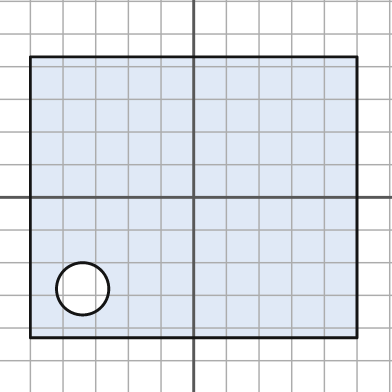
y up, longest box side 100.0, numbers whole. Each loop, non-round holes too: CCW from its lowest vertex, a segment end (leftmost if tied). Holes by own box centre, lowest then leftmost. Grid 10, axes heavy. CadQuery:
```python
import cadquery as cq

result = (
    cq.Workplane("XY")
    .moveTo(-50.0, -43.0)
    .lineTo(50.0, -43.0)
    .lineTo(50.0, 43.0)
    .lineTo(-50.0, 43.0)
    .close()
    .moveTo(-34.0, -28.0)
    .circle(8.0)
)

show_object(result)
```